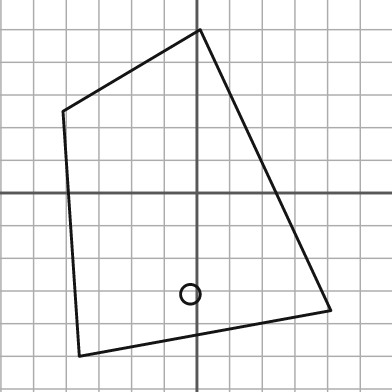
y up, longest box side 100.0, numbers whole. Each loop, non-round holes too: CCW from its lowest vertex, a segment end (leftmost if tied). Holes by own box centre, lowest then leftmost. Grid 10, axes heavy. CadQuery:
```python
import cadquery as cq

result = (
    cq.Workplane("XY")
    .moveTo(-36.0, -50.0)
    .lineTo(41.0, -36.0)
    .lineTo(1.0, 50.0)
    .lineTo(-41.0, 25.0)
    .close()
    .moveTo(-2.0, -31.0)
    .circle(3.0)
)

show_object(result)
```